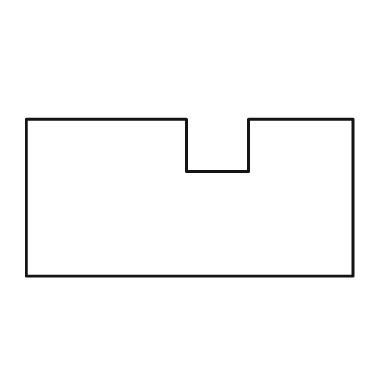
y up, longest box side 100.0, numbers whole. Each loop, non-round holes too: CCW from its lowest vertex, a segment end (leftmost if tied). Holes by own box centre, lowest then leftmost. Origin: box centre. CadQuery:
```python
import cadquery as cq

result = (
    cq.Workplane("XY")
    .moveTo(-50.0, -24.0)
    .lineTo(50.0, -24.0)
    .lineTo(50.0, 24.0)
    .lineTo(18.0, 24.0)
    .lineTo(18.0, 8.0)
    .lineTo(-1.0, 8.0)
    .lineTo(-1.0, 24.0)
    .lineTo(-50.0, 24.0)
    .close()
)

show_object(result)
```